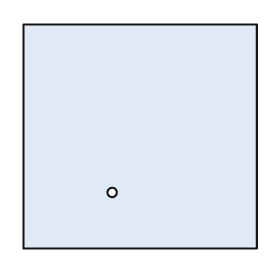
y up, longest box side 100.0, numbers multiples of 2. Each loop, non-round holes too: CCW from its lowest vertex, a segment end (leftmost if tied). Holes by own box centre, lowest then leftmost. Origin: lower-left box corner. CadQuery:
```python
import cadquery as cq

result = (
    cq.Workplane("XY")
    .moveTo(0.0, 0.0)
    .lineTo(100.0, 0.0)
    .lineTo(100.0, 96.0)
    .lineTo(0.0, 96.0)
    .close()
    .moveTo(38.0, 24.0)
    .circle(2.0)
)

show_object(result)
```